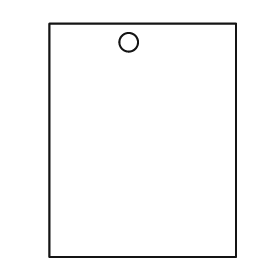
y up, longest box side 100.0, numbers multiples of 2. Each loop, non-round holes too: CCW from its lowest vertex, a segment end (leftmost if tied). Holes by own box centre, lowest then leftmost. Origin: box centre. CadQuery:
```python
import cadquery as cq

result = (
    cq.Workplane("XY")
    .moveTo(-40.0, -50.0)
    .lineTo(40.0, -50.0)
    .lineTo(40.0, 50.0)
    .lineTo(-40.0, 50.0)
    .close()
    .moveTo(-6.0, 42.0)
    .circle(4.0)
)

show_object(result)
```